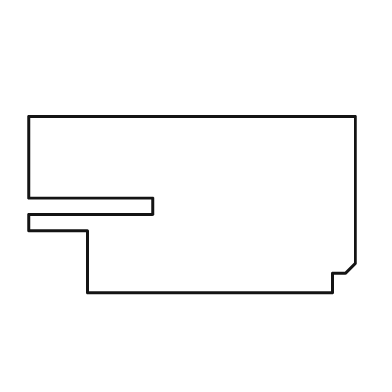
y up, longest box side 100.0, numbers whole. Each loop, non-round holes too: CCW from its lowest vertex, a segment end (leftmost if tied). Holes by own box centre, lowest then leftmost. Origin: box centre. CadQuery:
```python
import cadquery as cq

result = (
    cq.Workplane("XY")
    .moveTo(-32.0, -27.0)
    .lineTo(43.0, -27.0)
    .lineTo(43.0, -21.0)
    .lineTo(47.0, -21.0)
    .lineTo(50.0, -18.0)
    .lineTo(50.0, 27.0)
    .lineTo(-50.0, 27.0)
    .lineTo(-50.0, 2.0)
    .lineTo(-12.0, 2.0)
    .lineTo(-12.0, -3.0)
    .lineTo(-50.0, -3.0)
    .lineTo(-50.0, -8.0)
    .lineTo(-32.0, -8.0)
    .close()
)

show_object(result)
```